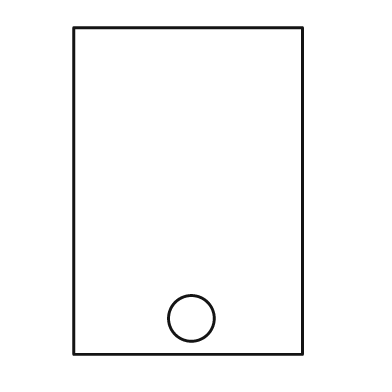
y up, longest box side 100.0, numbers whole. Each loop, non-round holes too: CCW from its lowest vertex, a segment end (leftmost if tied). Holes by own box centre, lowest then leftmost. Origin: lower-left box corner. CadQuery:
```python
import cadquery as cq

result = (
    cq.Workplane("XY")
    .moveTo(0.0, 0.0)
    .lineTo(70.0, 0.0)
    .lineTo(70.0, 100.0)
    .lineTo(0.0, 100.0)
    .close()
    .moveTo(36.0, 11.0)
    .circle(7.0)
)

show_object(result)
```